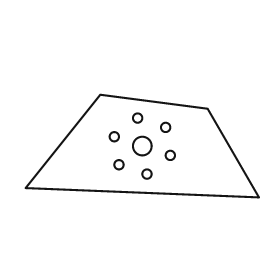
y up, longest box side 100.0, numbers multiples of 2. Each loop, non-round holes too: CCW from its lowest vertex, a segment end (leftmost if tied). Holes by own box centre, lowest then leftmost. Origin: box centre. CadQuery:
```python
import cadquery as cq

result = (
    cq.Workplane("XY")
    .moveTo(50.0, -22.0)
    .lineTo(28.0, 16.0)
    .lineTo(-18.0, 22.0)
    .lineTo(-50.0, -18.0)
    .close()
    .moveTo(2.0, -12.0)
    .circle(2.0)
    .moveTo(-10.0, -8.0)
    .circle(2.0)
    .moveTo(12.0, -4.0)
    .circle(2.0)
    .moveTo(0.0, 0.0)
    .circle(4.0)
    .moveTo(-12.0, 4.0)
    .circle(2.0)
    .moveTo(10.0, 8.0)
    .circle(2.0)
    .moveTo(-2.0, 12.0)
    .circle(2.0)
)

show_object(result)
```